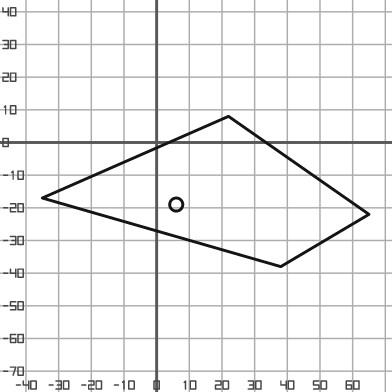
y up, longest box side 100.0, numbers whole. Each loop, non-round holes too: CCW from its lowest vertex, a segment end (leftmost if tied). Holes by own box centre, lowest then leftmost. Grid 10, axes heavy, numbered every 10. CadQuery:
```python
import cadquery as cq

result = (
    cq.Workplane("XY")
    .moveTo(38.0, -38.0)
    .lineTo(65.0, -22.0)
    .lineTo(22.0, 8.0)
    .lineTo(-35.0, -17.0)
    .close()
    .moveTo(6.0, -19.0)
    .circle(2.0)
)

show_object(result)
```